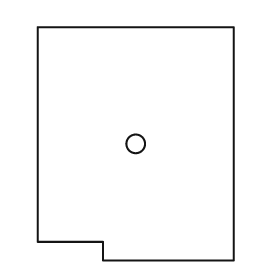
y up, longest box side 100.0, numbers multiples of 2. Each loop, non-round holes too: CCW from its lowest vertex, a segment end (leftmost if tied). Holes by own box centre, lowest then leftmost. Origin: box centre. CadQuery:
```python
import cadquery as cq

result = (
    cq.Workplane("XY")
    .moveTo(-14.0, -50.0)
    .lineTo(42.0, -50.0)
    .lineTo(42.0, 50.0)
    .lineTo(-42.0, 50.0)
    .lineTo(-42.0, -42.0)
    .lineTo(-14.0, -42.0)
    .close()
    .moveTo(0.0, 0.0)
    .circle(4.0)
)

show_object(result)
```